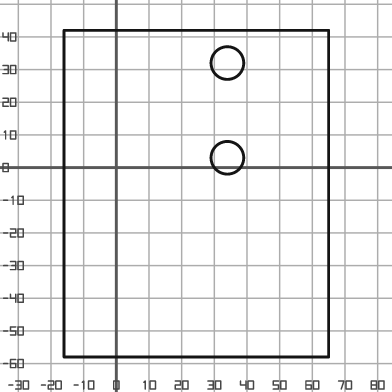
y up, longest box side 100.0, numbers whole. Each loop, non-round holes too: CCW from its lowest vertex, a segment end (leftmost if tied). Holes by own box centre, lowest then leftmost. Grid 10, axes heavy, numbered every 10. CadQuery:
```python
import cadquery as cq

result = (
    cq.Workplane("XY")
    .moveTo(-16.0, -58.0)
    .lineTo(65.0, -58.0)
    .lineTo(65.0, 42.0)
    .lineTo(-16.0, 42.0)
    .close()
    .moveTo(34.0, 3.0)
    .circle(5.0)
    .moveTo(34.0, 32.0)
    .circle(5.0)
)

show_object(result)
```